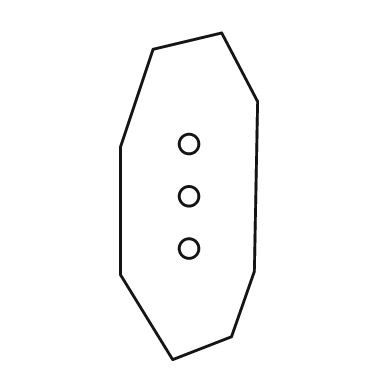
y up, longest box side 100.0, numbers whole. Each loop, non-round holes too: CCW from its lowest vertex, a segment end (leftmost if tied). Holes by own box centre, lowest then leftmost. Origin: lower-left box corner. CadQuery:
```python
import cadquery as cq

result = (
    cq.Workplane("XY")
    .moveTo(16.0, 0.0)
    .lineTo(34.0, 7.0)
    .lineTo(41.0, 27.0)
    .lineTo(42.0, 79.0)
    .lineTo(31.0, 100.0)
    .lineTo(10.0, 95.0)
    .lineTo(0.0, 65.0)
    .lineTo(0.0, 26.0)
    .close()
    .moveTo(21.0, 34.0)
    .circle(3.0)
    .moveTo(21.0, 50.0)
    .circle(3.0)
    .moveTo(21.0, 66.0)
    .circle(3.0)
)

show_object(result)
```